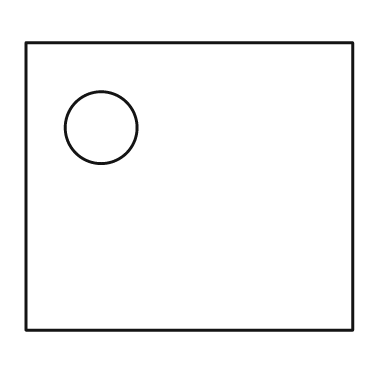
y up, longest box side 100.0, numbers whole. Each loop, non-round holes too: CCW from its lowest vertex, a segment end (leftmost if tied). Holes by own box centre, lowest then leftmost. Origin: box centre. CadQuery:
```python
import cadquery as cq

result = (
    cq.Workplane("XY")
    .moveTo(-50.0, -44.0)
    .lineTo(50.0, -44.0)
    .lineTo(50.0, 44.0)
    .lineTo(-50.0, 44.0)
    .close()
    .moveTo(-27.0, 18.0)
    .circle(11.0)
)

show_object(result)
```